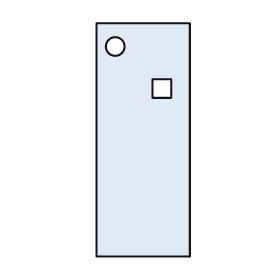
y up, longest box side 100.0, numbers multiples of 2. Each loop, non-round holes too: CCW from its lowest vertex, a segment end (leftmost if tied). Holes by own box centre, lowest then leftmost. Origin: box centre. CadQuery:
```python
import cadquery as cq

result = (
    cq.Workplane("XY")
    .moveTo(-20.0, -50.0)
    .lineTo(20.0, -50.0)
    .lineTo(20.0, 50.0)
    .lineTo(-20.0, 50.0)
    .close()
    .moveTo(4.0, 18.0)
    .lineTo(12.0, 18.0)
    .lineTo(12.0, 26.0)
    .lineTo(4.0, 26.0)
    .close()
    .moveTo(-12.0, 40.0)
    .circle(4.0)
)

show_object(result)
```